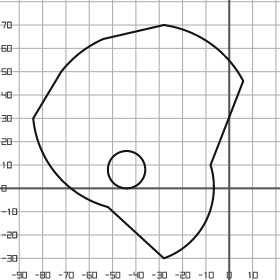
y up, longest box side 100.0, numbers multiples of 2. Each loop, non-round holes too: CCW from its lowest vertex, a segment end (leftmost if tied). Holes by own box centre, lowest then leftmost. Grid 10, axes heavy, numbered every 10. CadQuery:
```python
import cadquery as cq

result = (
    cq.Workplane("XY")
    .moveTo(-28.0, -30.0)
    .threePointArc((-10.0, -14.0), (-8.0, 10.0))
    .lineTo(6.0, 46.0)
    .threePointArc((-8.0, 62.0), (-28.0, 70.0))
    .lineTo(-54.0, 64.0)
    .threePointArc((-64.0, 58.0), (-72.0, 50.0))
    .lineTo(-84.0, 30.0)
    .threePointArc((-74.0, 6.0), (-52.0, -8.0))
    .close()
    .moveTo(-44.0, 8.0)
    .circle(8.0)
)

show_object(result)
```